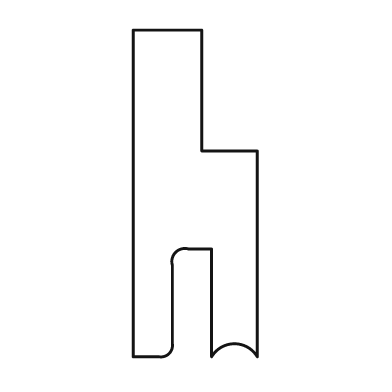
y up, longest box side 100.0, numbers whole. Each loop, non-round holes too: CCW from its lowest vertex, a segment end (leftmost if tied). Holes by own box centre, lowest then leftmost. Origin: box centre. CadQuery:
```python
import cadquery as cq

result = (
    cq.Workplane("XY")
    .moveTo(-19.0, -50.0)
    .lineTo(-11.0, -50.0)
    .threePointArc((-8.0, -49.0), (-7.0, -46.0))
    .lineTo(-7.0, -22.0)
    .threePointArc((-6.0, -18.0), (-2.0, -17.0))
    .lineTo(5.0, -17.0)
    .lineTo(5.0, -50.0)
    .threePointArc((12.0, -46.0), (19.0, -50.0))
    .lineTo(19.0, 13.0)
    .lineTo(2.0, 13.0)
    .lineTo(2.0, 50.0)
    .lineTo(-19.0, 50.0)
    .close()
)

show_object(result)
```